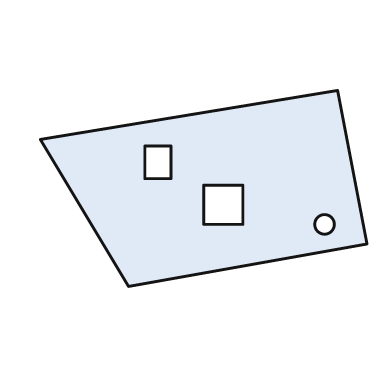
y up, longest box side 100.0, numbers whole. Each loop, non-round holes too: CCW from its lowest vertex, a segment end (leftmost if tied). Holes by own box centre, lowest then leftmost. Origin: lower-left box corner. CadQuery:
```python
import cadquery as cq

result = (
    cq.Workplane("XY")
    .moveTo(27.0, 0.0)
    .lineTo(100.0, 13.0)
    .lineTo(91.0, 60.0)
    .lineTo(0.0, 45.0)
    .close()
    .moveTo(87.0, 19.0)
    .circle(3.0)
    .moveTo(50.0, 19.0)
    .lineTo(62.0, 19.0)
    .lineTo(62.0, 31.0)
    .lineTo(50.0, 31.0)
    .close()
    .moveTo(32.0, 33.0)
    .lineTo(40.0, 33.0)
    .lineTo(40.0, 43.0)
    .lineTo(32.0, 43.0)
    .close()
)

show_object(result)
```